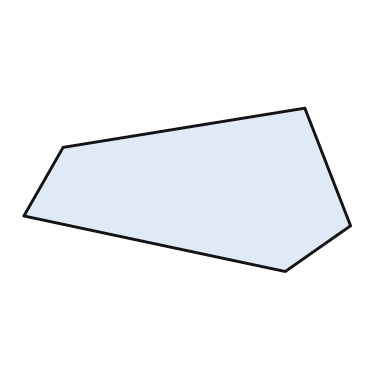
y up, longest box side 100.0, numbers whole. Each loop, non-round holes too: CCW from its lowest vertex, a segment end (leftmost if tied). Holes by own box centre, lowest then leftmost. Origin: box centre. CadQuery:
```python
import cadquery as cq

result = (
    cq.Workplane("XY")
    .moveTo(30.0, -25.0)
    .lineTo(50.0, -11.0)
    .lineTo(36.0, 25.0)
    .lineTo(-38.0, 13.0)
    .lineTo(-50.0, -8.0)
    .close()
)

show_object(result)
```